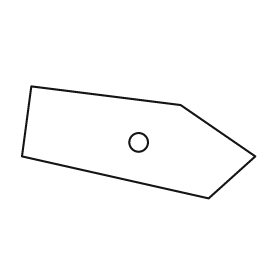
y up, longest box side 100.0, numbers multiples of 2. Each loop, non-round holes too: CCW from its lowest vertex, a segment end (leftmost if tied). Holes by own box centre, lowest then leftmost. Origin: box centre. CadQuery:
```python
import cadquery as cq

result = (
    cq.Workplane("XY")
    .moveTo(30.0, -24.0)
    .lineTo(50.0, -6.0)
    .lineTo(18.0, 16.0)
    .lineTo(-46.0, 24.0)
    .lineTo(-50.0, -6.0)
    .close()
    .moveTo(0.0, 0.0)
    .circle(4.0)
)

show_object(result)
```